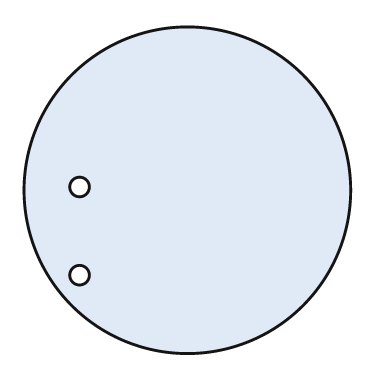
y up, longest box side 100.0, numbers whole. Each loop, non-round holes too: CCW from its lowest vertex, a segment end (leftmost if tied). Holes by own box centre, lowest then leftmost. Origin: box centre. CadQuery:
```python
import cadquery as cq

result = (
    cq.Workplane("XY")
    .moveTo(0.0, 0.0)
    .circle(50.0)
    .moveTo(-33.0, -26.0)
    .circle(3.0)
    .moveTo(-33.0, 1.0)
    .circle(3.0)
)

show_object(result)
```